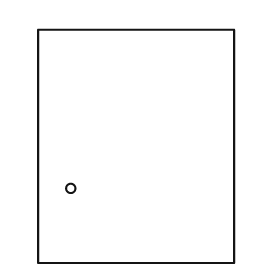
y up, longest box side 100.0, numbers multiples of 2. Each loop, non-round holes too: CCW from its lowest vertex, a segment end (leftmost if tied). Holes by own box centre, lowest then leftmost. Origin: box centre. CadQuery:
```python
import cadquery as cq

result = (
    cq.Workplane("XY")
    .moveTo(-42.0, -50.0)
    .lineTo(42.0, -50.0)
    .lineTo(42.0, 50.0)
    .lineTo(-42.0, 50.0)
    .close()
    .moveTo(-28.0, -18.0)
    .circle(2.0)
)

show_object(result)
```